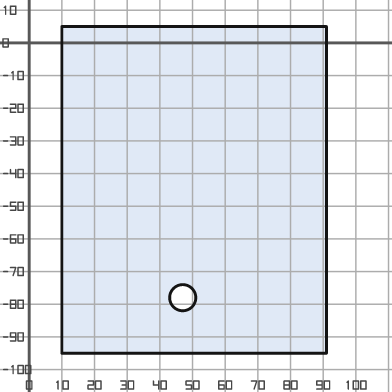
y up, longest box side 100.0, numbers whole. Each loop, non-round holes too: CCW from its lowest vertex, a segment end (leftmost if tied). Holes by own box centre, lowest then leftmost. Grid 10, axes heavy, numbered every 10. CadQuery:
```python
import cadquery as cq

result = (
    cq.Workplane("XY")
    .moveTo(10.0, -95.0)
    .lineTo(91.0, -95.0)
    .lineTo(91.0, 5.0)
    .lineTo(10.0, 5.0)
    .close()
    .moveTo(47.0, -78.0)
    .circle(4.0)
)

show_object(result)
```